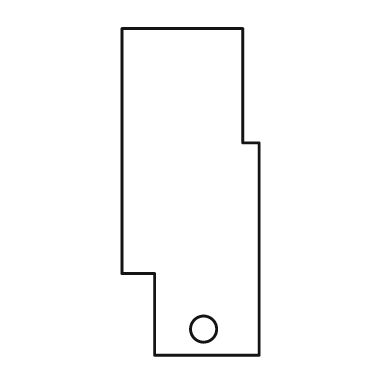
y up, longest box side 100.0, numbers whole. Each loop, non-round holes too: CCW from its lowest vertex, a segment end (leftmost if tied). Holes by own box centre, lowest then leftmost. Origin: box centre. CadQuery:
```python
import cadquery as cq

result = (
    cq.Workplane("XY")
    .moveTo(-11.0, -50.0)
    .lineTo(21.0, -50.0)
    .lineTo(21.0, 15.0)
    .lineTo(16.0, 15.0)
    .lineTo(16.0, 50.0)
    .lineTo(-21.0, 50.0)
    .lineTo(-21.0, -25.0)
    .lineTo(-11.0, -25.0)
    .close()
    .moveTo(4.0, -42.0)
    .circle(4.0)
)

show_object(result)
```